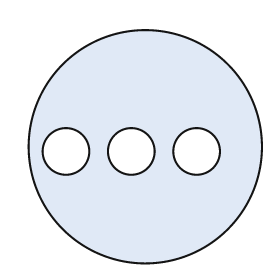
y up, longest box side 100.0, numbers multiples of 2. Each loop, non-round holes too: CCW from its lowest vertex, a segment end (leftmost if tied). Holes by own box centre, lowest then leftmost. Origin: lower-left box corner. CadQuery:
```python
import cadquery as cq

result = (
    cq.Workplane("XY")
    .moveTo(50.0, 50.0)
    .circle(50.0)
    .moveTo(16.0, 48.0)
    .circle(10.0)
    .moveTo(44.0, 48.0)
    .circle(10.0)
    .moveTo(72.0, 48.0)
    .circle(10.0)
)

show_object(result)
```